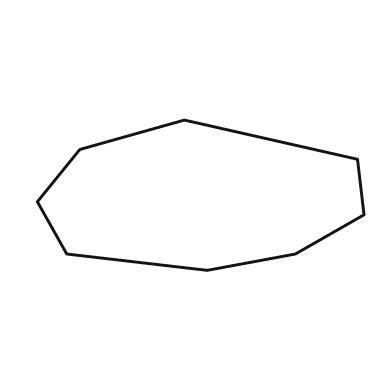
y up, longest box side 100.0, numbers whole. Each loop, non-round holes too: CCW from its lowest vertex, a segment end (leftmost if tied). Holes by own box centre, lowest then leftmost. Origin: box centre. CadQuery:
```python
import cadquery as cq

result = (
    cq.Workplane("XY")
    .moveTo(2.0, -23.0)
    .lineTo(29.0, -18.0)
    .lineTo(50.0, -6.0)
    .lineTo(48.0, 11.0)
    .lineTo(-5.0, 23.0)
    .lineTo(-37.0, 14.0)
    .lineTo(-50.0, -2.0)
    .lineTo(-41.0, -18.0)
    .close()
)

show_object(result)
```